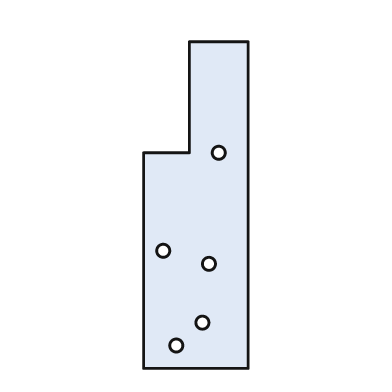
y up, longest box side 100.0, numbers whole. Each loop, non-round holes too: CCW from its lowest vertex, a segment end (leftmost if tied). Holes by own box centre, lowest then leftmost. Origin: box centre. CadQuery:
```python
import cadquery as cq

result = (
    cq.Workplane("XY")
    .moveTo(-16.0, -50.0)
    .lineTo(16.0, -50.0)
    .lineTo(16.0, 50.0)
    .lineTo(-2.0, 50.0)
    .lineTo(-2.0, 16.0)
    .lineTo(-16.0, 16.0)
    .close()
    .moveTo(-6.0, -43.0)
    .circle(2.0)
    .moveTo(2.0, -36.0)
    .circle(2.0)
    .moveTo(4.0, -18.0)
    .circle(2.0)
    .moveTo(-10.0, -14.0)
    .circle(2.0)
    .moveTo(7.0, 16.0)
    .circle(2.0)
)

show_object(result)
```